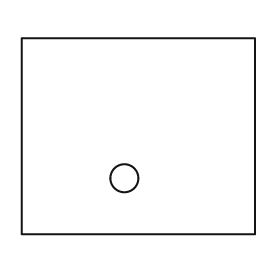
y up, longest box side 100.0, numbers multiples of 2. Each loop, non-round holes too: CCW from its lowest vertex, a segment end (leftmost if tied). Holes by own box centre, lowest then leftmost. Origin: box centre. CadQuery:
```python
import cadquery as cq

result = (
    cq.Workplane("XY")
    .moveTo(-50.0, -42.0)
    .lineTo(50.0, -42.0)
    .lineTo(50.0, 42.0)
    .lineTo(-50.0, 42.0)
    .close()
    .moveTo(-6.0, -18.0)
    .circle(6.0)
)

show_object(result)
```